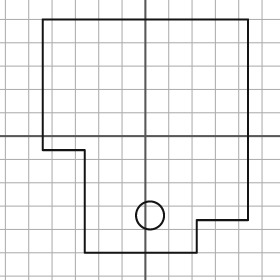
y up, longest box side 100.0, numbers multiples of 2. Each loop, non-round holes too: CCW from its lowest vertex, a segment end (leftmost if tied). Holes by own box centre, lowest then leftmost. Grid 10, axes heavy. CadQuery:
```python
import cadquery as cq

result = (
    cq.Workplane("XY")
    .moveTo(-26.0, -50.0)
    .lineTo(22.0, -50.0)
    .lineTo(22.0, -36.0)
    .lineTo(44.0, -36.0)
    .lineTo(44.0, 50.0)
    .lineTo(-44.0, 50.0)
    .lineTo(-44.0, -6.0)
    .lineTo(-26.0, -6.0)
    .close()
    .moveTo(2.0, -34.0)
    .circle(6.0)
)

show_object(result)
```